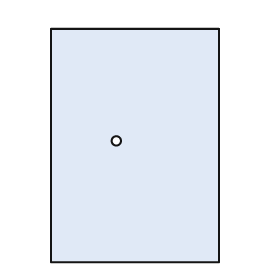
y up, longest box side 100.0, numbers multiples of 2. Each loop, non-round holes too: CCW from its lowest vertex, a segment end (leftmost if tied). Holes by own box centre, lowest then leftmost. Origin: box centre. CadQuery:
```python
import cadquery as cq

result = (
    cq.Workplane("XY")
    .moveTo(-36.0, -50.0)
    .lineTo(36.0, -50.0)
    .lineTo(36.0, 50.0)
    .lineTo(-36.0, 50.0)
    .close()
    .moveTo(-8.0, 2.0)
    .circle(2.0)
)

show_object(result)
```